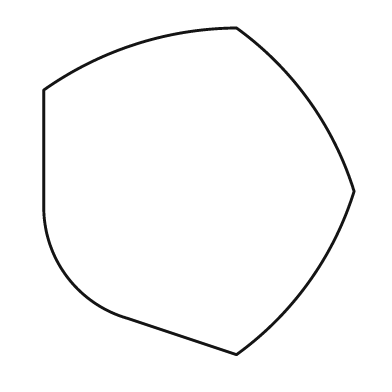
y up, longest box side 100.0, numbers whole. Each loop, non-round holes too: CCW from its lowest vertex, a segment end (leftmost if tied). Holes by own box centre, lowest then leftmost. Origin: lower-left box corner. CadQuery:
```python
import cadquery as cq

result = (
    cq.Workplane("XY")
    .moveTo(59.0, 0.0)
    .threePointArc((81.0, 22.0), (95.0, 50.0))
    .threePointArc((81.0, 78.0), (59.0, 100.0))
    .threePointArc((28.0, 95.0), (0.0, 81.0))
    .lineTo(0.0, 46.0)
    .threePointArc((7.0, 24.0), (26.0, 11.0))
    .close()
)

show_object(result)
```